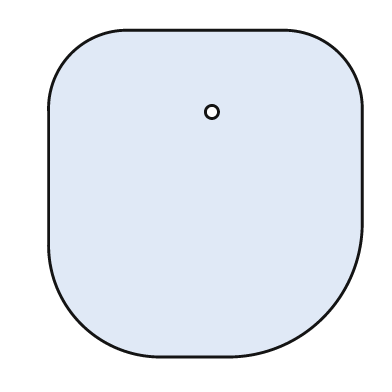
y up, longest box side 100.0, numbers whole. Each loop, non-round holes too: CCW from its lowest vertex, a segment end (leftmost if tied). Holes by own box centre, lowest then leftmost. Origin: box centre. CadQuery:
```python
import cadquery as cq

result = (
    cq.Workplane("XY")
    .moveTo(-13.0, -50.0)
    .lineTo(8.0, -50.0)
    .threePointArc((36.0, -38.0), (48.0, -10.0))
    .lineTo(48.0, 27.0)
    .threePointArc((41.0, 43.0), (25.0, 50.0))
    .lineTo(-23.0, 50.0)
    .threePointArc((-41.0, 43.0), (-48.0, 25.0))
    .lineTo(-48.0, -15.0)
    .threePointArc((-38.0, -40.0), (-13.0, -50.0))
    .close()
    .moveTo(2.0, 25.0)
    .circle(2.0)
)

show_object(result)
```